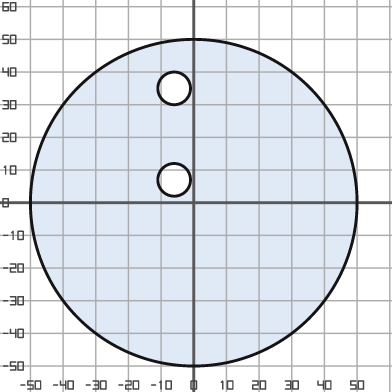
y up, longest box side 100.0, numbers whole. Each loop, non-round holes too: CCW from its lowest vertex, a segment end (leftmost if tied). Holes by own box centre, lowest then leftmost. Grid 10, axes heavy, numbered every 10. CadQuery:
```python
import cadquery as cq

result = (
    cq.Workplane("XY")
    .moveTo(0.0, 0.0)
    .circle(50.0)
    .moveTo(-6.0, 7.0)
    .circle(5.0)
    .moveTo(-6.0, 35.0)
    .circle(5.0)
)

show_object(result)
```